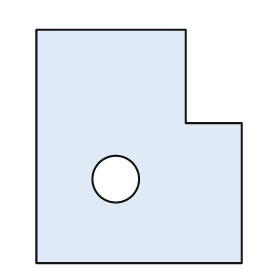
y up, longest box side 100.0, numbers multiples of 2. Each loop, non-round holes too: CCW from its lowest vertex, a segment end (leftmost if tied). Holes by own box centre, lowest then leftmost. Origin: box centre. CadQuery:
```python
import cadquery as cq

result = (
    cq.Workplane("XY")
    .moveTo(-44.0, -50.0)
    .lineTo(44.0, -50.0)
    .lineTo(44.0, 10.0)
    .lineTo(20.0, 10.0)
    .lineTo(20.0, 50.0)
    .lineTo(-44.0, 50.0)
    .close()
    .moveTo(-10.0, -14.0)
    .circle(10.0)
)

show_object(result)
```